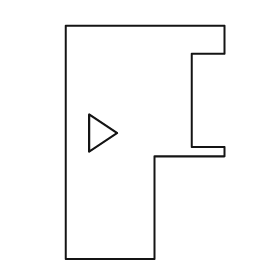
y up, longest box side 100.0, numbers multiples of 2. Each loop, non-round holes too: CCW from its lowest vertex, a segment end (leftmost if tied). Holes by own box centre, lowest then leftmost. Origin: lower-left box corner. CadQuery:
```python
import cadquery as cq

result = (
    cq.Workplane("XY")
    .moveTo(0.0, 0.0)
    .lineTo(38.0, 0.0)
    .lineTo(38.0, 44.0)
    .lineTo(68.0, 44.0)
    .lineTo(68.0, 48.0)
    .lineTo(54.0, 48.0)
    .lineTo(54.0, 88.0)
    .lineTo(68.0, 88.0)
    .lineTo(68.0, 100.0)
    .lineTo(0.0, 100.0)
    .close()
    .moveTo(10.0, 46.0)
    .lineTo(22.0, 54.0)
    .lineTo(10.0, 62.0)
    .close()
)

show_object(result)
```